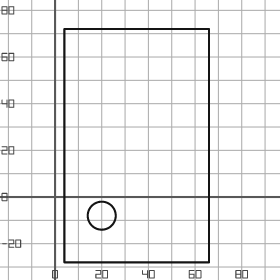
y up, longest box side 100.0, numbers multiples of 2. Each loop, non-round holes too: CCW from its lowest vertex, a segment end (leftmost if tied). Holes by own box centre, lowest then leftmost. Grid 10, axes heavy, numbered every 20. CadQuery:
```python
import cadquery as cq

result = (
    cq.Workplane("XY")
    .moveTo(4.0, -28.0)
    .lineTo(66.0, -28.0)
    .lineTo(66.0, 72.0)
    .lineTo(4.0, 72.0)
    .close()
    .moveTo(20.0, -8.0)
    .circle(6.0)
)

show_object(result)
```